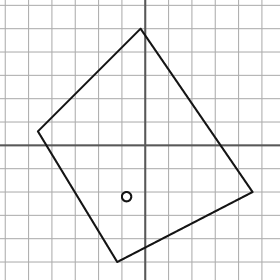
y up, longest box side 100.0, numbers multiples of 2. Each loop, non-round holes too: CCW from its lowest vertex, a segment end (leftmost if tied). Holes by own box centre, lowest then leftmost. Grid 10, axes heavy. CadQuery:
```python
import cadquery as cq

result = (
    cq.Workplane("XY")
    .moveTo(-12.0, -50.0)
    .lineTo(46.0, -20.0)
    .lineTo(-2.0, 50.0)
    .lineTo(-46.0, 6.0)
    .close()
    .moveTo(-8.0, -22.0)
    .circle(2.0)
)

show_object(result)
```